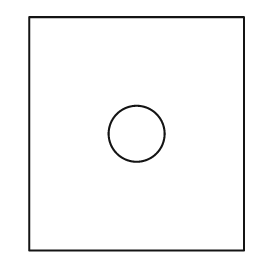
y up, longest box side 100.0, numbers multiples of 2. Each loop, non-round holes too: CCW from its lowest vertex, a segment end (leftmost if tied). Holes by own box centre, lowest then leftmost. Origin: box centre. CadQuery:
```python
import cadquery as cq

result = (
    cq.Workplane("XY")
    .moveTo(-46.0, -50.0)
    .lineTo(46.0, -50.0)
    .lineTo(46.0, 50.0)
    .lineTo(-46.0, 50.0)
    .close()
    .moveTo(0.0, 0.0)
    .circle(12.0)
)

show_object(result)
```